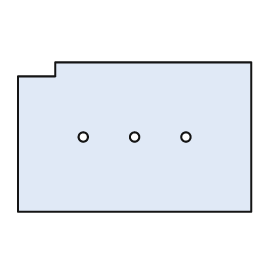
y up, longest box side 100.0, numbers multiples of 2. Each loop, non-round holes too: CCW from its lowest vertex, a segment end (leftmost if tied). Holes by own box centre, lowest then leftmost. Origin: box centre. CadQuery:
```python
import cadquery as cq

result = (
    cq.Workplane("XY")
    .moveTo(-50.0, -32.0)
    .lineTo(50.0, -32.0)
    .lineTo(50.0, 32.0)
    .lineTo(-34.0, 32.0)
    .lineTo(-34.0, 26.0)
    .lineTo(-50.0, 26.0)
    .close()
    .moveTo(-22.0, 0.0)
    .circle(2.0)
    .moveTo(0.0, 0.0)
    .circle(2.0)
    .moveTo(22.0, 0.0)
    .circle(2.0)
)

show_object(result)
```